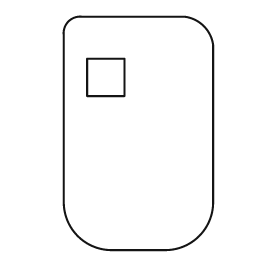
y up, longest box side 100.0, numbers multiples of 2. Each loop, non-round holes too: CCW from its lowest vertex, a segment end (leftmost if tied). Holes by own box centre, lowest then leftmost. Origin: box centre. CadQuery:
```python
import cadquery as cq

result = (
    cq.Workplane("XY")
    .moveTo(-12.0, -50.0)
    .lineTo(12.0, -50.0)
    .threePointArc((26.0, -44.0), (32.0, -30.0))
    .lineTo(32.0, 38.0)
    .threePointArc((28.0, 46.0), (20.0, 50.0))
    .lineTo(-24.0, 50.0)
    .threePointArc((-30.0, 48.0), (-32.0, 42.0))
    .lineTo(-32.0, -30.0)
    .threePointArc((-26.0, -44.0), (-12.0, -50.0))
    .close()
    .moveTo(-22.0, 16.0)
    .lineTo(-6.0, 16.0)
    .lineTo(-6.0, 32.0)
    .lineTo(-22.0, 32.0)
    .close()
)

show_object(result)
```